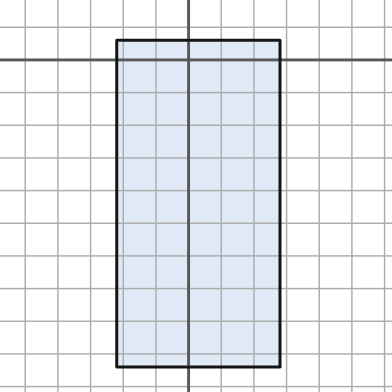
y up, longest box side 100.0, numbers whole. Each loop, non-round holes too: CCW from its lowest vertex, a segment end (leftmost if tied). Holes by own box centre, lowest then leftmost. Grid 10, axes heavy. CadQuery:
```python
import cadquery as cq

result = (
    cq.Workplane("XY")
    .moveTo(-22.0, -94.0)
    .lineTo(28.0, -94.0)
    .lineTo(28.0, 6.0)
    .lineTo(-22.0, 6.0)
    .close()
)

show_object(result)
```